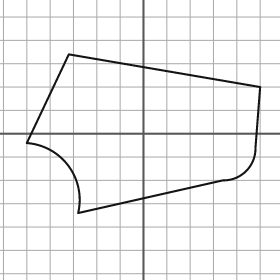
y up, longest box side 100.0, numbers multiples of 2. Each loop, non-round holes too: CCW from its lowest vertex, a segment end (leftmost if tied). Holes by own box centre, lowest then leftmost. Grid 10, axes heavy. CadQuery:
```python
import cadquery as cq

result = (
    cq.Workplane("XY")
    .moveTo(-28.0, -34.0)
    .lineTo(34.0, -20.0)
    .threePointArc((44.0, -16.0), (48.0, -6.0))
    .lineTo(50.0, 20.0)
    .lineTo(-32.0, 34.0)
    .lineTo(-50.0, -4.0)
    .threePointArc((-32.0, -14.0), (-28.0, -34.0))
    .close()
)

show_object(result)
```